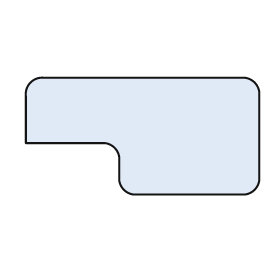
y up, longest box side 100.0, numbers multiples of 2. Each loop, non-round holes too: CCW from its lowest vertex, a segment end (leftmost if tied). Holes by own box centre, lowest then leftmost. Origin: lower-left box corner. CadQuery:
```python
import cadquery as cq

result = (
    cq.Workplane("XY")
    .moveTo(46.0, 0.0)
    .lineTo(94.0, 0.0)
    .threePointArc((98.0, 2.0), (100.0, 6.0))
    .lineTo(100.0, 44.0)
    .threePointArc((98.0, 48.0), (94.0, 50.0))
    .lineTo(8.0, 50.0)
    .threePointArc((2.0, 48.0), (0.0, 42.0))
    .lineTo(0.0, 22.0)
    .lineTo(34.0, 22.0)
    .threePointArc((38.0, 20.0), (40.0, 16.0))
    .lineTo(40.0, 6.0)
    .threePointArc((42.0, 2.0), (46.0, 0.0))
    .close()
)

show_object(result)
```